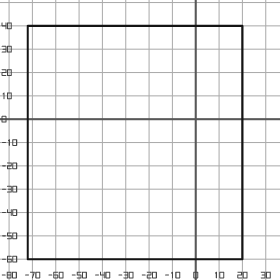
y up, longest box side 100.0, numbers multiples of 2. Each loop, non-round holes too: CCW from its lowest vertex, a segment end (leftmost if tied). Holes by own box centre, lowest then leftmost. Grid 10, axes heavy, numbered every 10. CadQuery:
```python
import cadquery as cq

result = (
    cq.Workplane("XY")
    .moveTo(-72.0, -60.0)
    .lineTo(20.0, -60.0)
    .lineTo(20.0, 40.0)
    .lineTo(-72.0, 40.0)
    .close()
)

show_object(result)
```